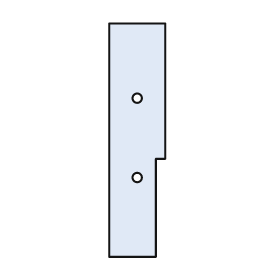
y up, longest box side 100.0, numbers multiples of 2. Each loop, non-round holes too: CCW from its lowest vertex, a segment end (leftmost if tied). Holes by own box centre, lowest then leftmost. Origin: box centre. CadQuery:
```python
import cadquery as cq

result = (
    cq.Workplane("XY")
    .moveTo(-12.0, -50.0)
    .lineTo(8.0, -50.0)
    .lineTo(8.0, -8.0)
    .lineTo(12.0, -8.0)
    .lineTo(12.0, 50.0)
    .lineTo(-12.0, 50.0)
    .close()
    .moveTo(0.0, -16.0)
    .circle(2.0)
    .moveTo(0.0, 18.0)
    .circle(2.0)
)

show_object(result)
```